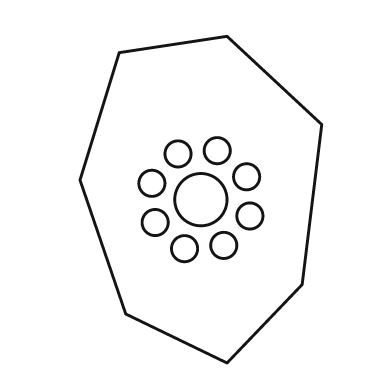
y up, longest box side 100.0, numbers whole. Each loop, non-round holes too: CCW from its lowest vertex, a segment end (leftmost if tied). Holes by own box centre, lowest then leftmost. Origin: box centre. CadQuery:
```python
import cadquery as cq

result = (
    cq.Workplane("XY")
    .moveTo(8.0, -50.0)
    .lineTo(31.0, -26.0)
    .lineTo(37.0, 23.0)
    .lineTo(8.0, 50.0)
    .lineTo(-25.0, 45.0)
    .lineTo(-37.0, 6.0)
    .lineTo(-23.0, -35.0)
    .close()
    .moveTo(-5.0, -15.0)
    .circle(4.0)
    .moveTo(7.0, -14.0)
    .circle(4.0)
    .moveTo(-14.0, -7.0)
    .circle(4.0)
    .moveTo(15.0, -5.0)
    .circle(4.0)
    .moveTo(0.0, 0.0)
    .circle(8.0)
    .moveTo(-15.0, 5.0)
    .circle(4.0)
    .moveTo(14.0, 7.0)
    .circle(4.0)
    .moveTo(-7.0, 14.0)
    .circle(4.0)
    .moveTo(5.0, 15.0)
    .circle(4.0)
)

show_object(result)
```